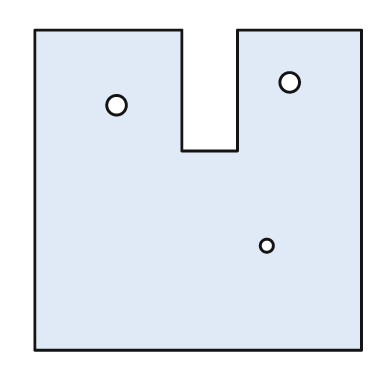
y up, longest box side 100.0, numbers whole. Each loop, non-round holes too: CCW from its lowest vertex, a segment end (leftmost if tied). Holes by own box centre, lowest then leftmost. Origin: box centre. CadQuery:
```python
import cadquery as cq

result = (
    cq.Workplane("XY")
    .moveTo(-50.0, -49.0)
    .lineTo(50.0, -49.0)
    .lineTo(50.0, 49.0)
    .lineTo(12.0, 49.0)
    .lineTo(12.0, 12.0)
    .lineTo(-5.0, 12.0)
    .lineTo(-5.0, 49.0)
    .lineTo(-50.0, 49.0)
    .close()
    .moveTo(21.0, -17.0)
    .circle(2.0)
    .moveTo(-25.0, 26.0)
    .circle(3.0)
    .moveTo(28.0, 33.0)
    .circle(3.0)
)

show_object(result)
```